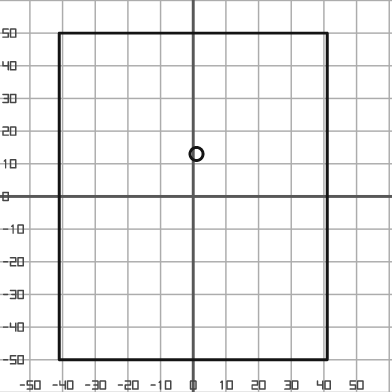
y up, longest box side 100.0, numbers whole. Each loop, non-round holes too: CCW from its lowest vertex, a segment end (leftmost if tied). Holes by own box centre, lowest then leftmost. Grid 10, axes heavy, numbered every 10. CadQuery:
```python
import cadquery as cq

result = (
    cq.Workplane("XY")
    .moveTo(-41.0, -50.0)
    .lineTo(41.0, -50.0)
    .lineTo(41.0, 50.0)
    .lineTo(-41.0, 50.0)
    .close()
    .moveTo(1.0, 13.0)
    .circle(2.0)
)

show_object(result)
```